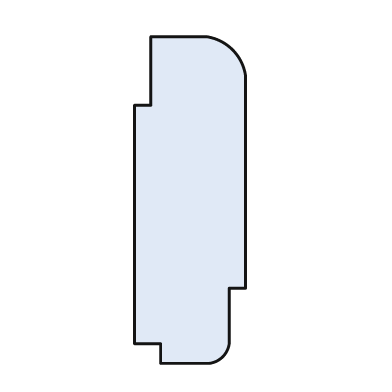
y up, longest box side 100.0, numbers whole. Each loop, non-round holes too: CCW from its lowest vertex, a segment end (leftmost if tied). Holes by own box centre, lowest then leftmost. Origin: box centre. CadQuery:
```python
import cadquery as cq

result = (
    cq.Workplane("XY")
    .moveTo(-9.0, -50.0)
    .lineTo(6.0, -50.0)
    .threePointArc((10.0, -48.0), (12.0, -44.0))
    .lineTo(12.0, -27.0)
    .lineTo(17.0, -27.0)
    .lineTo(17.0, 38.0)
    .threePointArc((13.0, 46.0), (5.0, 50.0))
    .lineTo(-12.0, 50.0)
    .lineTo(-12.0, 29.0)
    .lineTo(-17.0, 29.0)
    .lineTo(-17.0, -44.0)
    .lineTo(-9.0, -44.0)
    .close()
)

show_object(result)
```